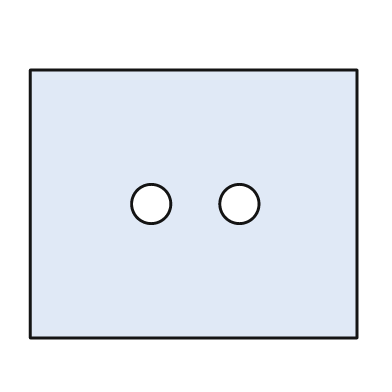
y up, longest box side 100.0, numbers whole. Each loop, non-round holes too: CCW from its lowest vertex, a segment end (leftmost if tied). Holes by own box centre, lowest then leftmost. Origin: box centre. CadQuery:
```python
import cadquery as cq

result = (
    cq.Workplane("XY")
    .moveTo(-50.0, -41.0)
    .lineTo(50.0, -41.0)
    .lineTo(50.0, 41.0)
    .lineTo(-50.0, 41.0)
    .close()
    .moveTo(-13.0, 0.0)
    .circle(6.0)
    .moveTo(14.0, 0.0)
    .circle(6.0)
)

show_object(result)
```